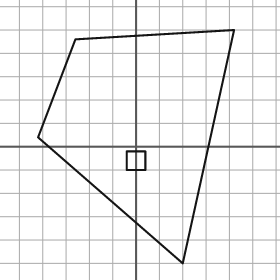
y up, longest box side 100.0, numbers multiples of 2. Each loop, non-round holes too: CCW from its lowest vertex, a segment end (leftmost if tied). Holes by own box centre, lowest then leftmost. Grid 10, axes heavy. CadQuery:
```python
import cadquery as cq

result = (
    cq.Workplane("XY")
    .moveTo(20.0, -50.0)
    .lineTo(42.0, 50.0)
    .lineTo(-26.0, 46.0)
    .lineTo(-42.0, 4.0)
    .close()
    .moveTo(-4.0, -10.0)
    .lineTo(4.0, -10.0)
    .lineTo(4.0, -2.0)
    .lineTo(-4.0, -2.0)
    .close()
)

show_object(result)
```